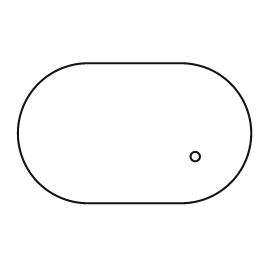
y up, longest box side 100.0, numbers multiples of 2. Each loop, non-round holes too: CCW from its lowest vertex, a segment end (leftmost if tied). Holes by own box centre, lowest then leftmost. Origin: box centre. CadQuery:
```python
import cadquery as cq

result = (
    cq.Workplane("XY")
    .moveTo(-20.0, -30.0)
    .lineTo(20.0, -30.0)
    .threePointArc((50.0, 0.0), (20.0, 30.0))
    .lineTo(-20.0, 30.0)
    .threePointArc((-50.0, 0.0), (-20.0, -30.0))
    .close()
    .moveTo(26.0, -10.0)
    .circle(2.0)
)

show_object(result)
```